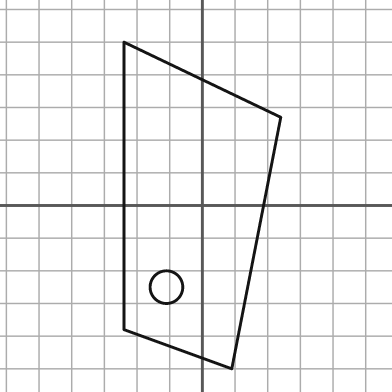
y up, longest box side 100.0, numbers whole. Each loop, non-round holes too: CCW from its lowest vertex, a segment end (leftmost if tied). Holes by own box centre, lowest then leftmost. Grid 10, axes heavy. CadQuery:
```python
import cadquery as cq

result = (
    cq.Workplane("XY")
    .moveTo(9.0, -50.0)
    .lineTo(24.0, 27.0)
    .lineTo(-24.0, 50.0)
    .lineTo(-24.0, -38.0)
    .close()
    .moveTo(-11.0, -25.0)
    .circle(5.0)
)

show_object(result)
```